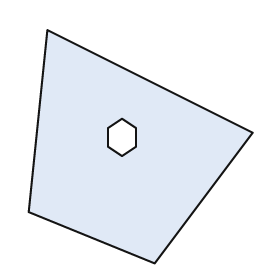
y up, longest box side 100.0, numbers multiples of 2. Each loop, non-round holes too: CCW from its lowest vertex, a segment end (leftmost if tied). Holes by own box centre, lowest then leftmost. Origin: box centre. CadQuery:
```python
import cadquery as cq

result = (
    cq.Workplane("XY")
    .moveTo(6.0, -50.0)
    .lineTo(48.0, 6.0)
    .lineTo(-40.0, 50.0)
    .lineTo(-48.0, -28.0)
    .close()
    .moveTo(-8.0, -4.0)
    .lineTo(-2.0, 0.0)
    .lineTo(-2.0, 8.0)
    .lineTo(-8.0, 12.0)
    .lineTo(-14.0, 8.0)
    .lineTo(-14.0, 0.0)
    .close()
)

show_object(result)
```